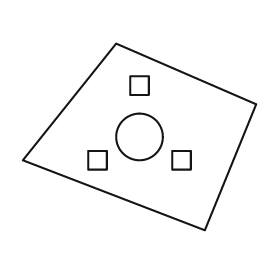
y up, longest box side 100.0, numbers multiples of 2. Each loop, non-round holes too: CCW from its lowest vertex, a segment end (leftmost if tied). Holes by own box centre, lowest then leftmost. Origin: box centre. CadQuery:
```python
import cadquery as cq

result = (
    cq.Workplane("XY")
    .moveTo(28.0, -40.0)
    .lineTo(50.0, 14.0)
    .lineTo(-10.0, 40.0)
    .lineTo(-50.0, -10.0)
    .close()
    .moveTo(-22.0, -14.0)
    .lineTo(-14.0, -14.0)
    .lineTo(-14.0, -6.0)
    .lineTo(-22.0, -6.0)
    .close()
    .moveTo(14.0, -14.0)
    .lineTo(22.0, -14.0)
    .lineTo(22.0, -6.0)
    .lineTo(14.0, -6.0)
    .close()
    .moveTo(0.0, 0.0)
    .circle(10.0)
    .moveTo(-4.0, 18.0)
    .lineTo(4.0, 18.0)
    .lineTo(4.0, 26.0)
    .lineTo(-4.0, 26.0)
    .close()
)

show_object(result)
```